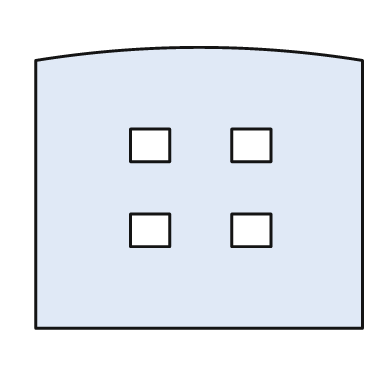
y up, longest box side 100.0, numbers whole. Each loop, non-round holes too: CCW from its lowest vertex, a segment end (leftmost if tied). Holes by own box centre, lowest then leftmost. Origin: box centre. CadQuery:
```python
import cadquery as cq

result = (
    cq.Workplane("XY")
    .moveTo(-50.0, -43.0)
    .lineTo(50.0, -43.0)
    .lineTo(50.0, 39.0)
    .threePointArc((0.0, 43.0), (-50.0, 39.0))
    .close()
    .moveTo(-21.0, -18.0)
    .lineTo(-9.0, -18.0)
    .lineTo(-9.0, -8.0)
    .lineTo(-21.0, -8.0)
    .close()
    .moveTo(10.0, -18.0)
    .lineTo(22.0, -18.0)
    .lineTo(22.0, -8.0)
    .lineTo(10.0, -8.0)
    .close()
    .moveTo(-21.0, 8.0)
    .lineTo(-9.0, 8.0)
    .lineTo(-9.0, 18.0)
    .lineTo(-21.0, 18.0)
    .close()
    .moveTo(10.0, 8.0)
    .lineTo(22.0, 8.0)
    .lineTo(22.0, 18.0)
    .lineTo(10.0, 18.0)
    .close()
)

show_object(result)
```